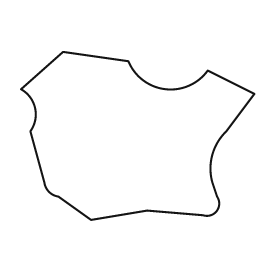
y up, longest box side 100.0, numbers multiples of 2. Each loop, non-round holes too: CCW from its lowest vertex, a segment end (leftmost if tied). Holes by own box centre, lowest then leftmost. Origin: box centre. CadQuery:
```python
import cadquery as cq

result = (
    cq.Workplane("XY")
    .moveTo(-20.0, -36.0)
    .lineTo(4.0, -32.0)
    .lineTo(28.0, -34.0)
    .threePointArc((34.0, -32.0), (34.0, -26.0))
    .lineTo(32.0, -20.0)
    .threePointArc((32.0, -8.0), (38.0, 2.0))
    .lineTo(50.0, 18.0)
    .lineTo(30.0, 28.0)
    .threePointArc((12.0, 20.0), (-4.0, 32.0))
    .lineTo(-32.0, 36.0)
    .lineTo(-50.0, 20.0)
    .threePointArc((-44.0, 12.0), (-46.0, 2.0))
    .lineTo(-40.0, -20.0)
    .threePointArc((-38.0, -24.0), (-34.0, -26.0))
    .close()
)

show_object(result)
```